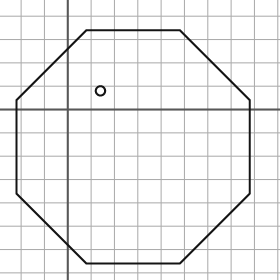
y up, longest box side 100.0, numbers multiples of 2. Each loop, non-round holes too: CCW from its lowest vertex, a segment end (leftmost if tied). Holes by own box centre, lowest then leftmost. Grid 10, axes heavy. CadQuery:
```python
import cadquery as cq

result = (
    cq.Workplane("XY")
    .moveTo(8.0, -66.0)
    .lineTo(48.0, -66.0)
    .lineTo(78.0, -36.0)
    .lineTo(78.0, 4.0)
    .lineTo(48.0, 34.0)
    .lineTo(8.0, 34.0)
    .lineTo(-22.0, 4.0)
    .lineTo(-22.0, -36.0)
    .close()
    .moveTo(14.0, 8.0)
    .circle(2.0)
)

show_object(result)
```